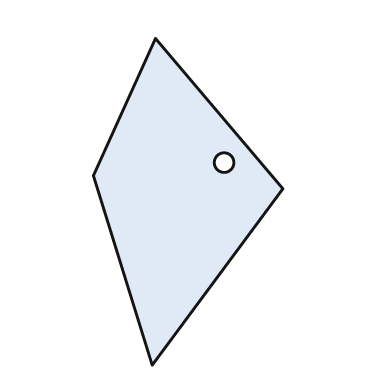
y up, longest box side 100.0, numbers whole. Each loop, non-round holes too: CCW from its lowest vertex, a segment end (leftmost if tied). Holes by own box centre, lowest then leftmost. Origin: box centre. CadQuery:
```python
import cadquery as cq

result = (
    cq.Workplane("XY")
    .moveTo(-11.0, -50.0)
    .lineTo(29.0, 4.0)
    .lineTo(-10.0, 50.0)
    .lineTo(-29.0, 8.0)
    .close()
    .moveTo(11.0, 12.0)
    .circle(3.0)
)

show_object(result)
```